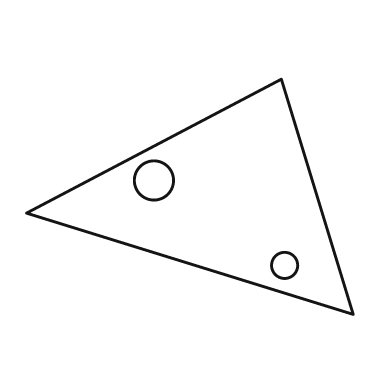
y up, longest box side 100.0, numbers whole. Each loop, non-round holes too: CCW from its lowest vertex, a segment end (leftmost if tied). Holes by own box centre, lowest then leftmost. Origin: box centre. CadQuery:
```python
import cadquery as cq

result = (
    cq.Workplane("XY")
    .moveTo(50.0, -36.0)
    .lineTo(28.0, 36.0)
    .lineTo(-50.0, -5.0)
    .close()
    .moveTo(29.0, -21.0)
    .circle(4.0)
    .moveTo(-11.0, 5.0)
    .circle(6.0)
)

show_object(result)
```